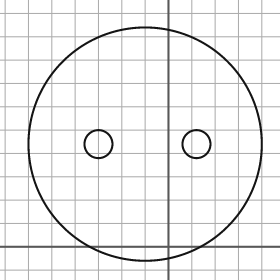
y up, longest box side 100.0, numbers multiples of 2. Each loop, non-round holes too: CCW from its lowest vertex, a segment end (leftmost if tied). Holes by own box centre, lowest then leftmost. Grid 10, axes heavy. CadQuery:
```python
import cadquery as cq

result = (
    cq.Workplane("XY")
    .moveTo(-10.0, 44.0)
    .circle(50.0)
    .moveTo(-30.0, 44.0)
    .circle(6.0)
    .moveTo(12.0, 44.0)
    .circle(6.0)
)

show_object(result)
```